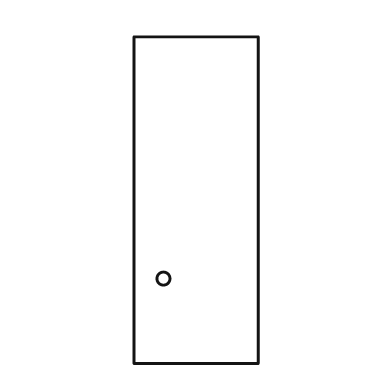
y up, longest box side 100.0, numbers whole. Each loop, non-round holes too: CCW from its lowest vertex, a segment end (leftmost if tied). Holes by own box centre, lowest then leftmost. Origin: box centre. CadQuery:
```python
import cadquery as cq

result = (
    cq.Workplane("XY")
    .moveTo(-19.0, -50.0)
    .lineTo(19.0, -50.0)
    .lineTo(19.0, 50.0)
    .lineTo(-19.0, 50.0)
    .close()
    .moveTo(-10.0, -24.0)
    .circle(2.0)
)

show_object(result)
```